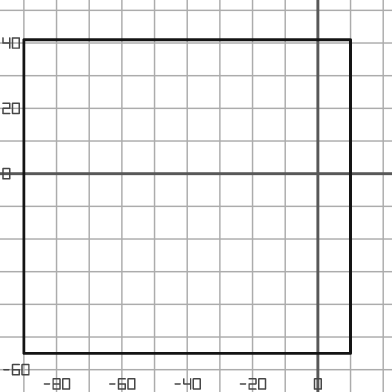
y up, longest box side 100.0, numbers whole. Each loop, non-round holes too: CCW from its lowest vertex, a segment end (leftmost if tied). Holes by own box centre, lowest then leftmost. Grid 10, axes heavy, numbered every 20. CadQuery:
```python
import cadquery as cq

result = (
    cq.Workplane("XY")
    .moveTo(-90.0, -55.0)
    .lineTo(10.0, -55.0)
    .lineTo(10.0, 41.0)
    .lineTo(-90.0, 41.0)
    .close()
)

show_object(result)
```